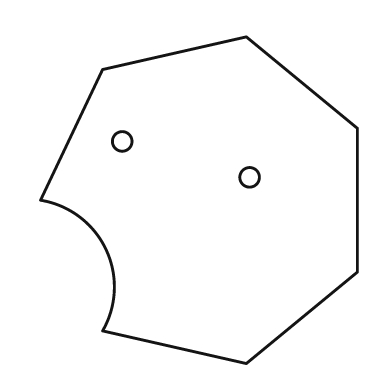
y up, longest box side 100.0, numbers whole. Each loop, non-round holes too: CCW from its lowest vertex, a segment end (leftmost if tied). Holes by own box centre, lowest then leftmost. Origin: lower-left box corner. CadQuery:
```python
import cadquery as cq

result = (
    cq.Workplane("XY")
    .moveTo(63.0, 0.0)
    .lineTo(97.0, 28.0)
    .lineTo(97.0, 72.0)
    .lineTo(63.0, 100.0)
    .lineTo(19.0, 90.0)
    .lineTo(0.0, 50.0)
    .threePointArc((20.0, 35.0), (19.0, 10.0))
    .close()
    .moveTo(64.0, 57.0)
    .circle(3.0)
    .moveTo(25.0, 68.0)
    .circle(3.0)
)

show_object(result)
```